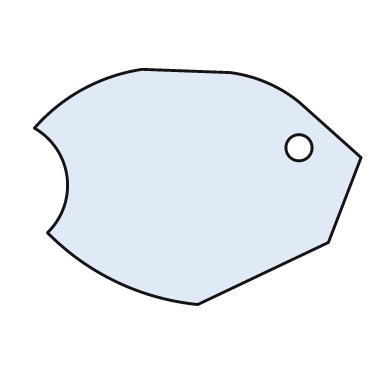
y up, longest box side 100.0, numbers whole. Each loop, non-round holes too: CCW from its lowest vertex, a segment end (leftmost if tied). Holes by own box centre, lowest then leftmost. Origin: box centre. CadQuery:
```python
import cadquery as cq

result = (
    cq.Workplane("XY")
    .moveTo(0.0, -36.0)
    .lineTo(40.0, -17.0)
    .lineTo(50.0, 9.0)
    .lineTo(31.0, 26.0)
    .threePointArc((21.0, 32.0), (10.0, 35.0))
    .lineTo(-17.0, 36.0)
    .threePointArc((-35.0, 30.0), (-50.0, 18.0))
    .threePointArc((-40.0, 3.0), (-46.0, -14.0))
    .threePointArc((-25.0, -29.0), (0.0, -36.0))
    .close()
    .moveTo(31.0, 12.0)
    .circle(4.0)
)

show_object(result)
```